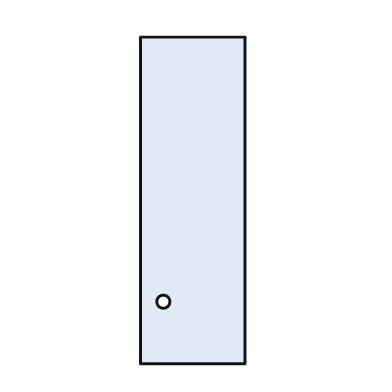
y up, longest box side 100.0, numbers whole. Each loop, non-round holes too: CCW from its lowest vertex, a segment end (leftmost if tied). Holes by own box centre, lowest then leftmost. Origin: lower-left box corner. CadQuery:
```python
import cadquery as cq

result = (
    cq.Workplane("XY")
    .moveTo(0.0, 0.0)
    .lineTo(32.0, 0.0)
    .lineTo(32.0, 100.0)
    .lineTo(0.0, 100.0)
    .close()
    .moveTo(7.0, 19.0)
    .circle(2.0)
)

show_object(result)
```